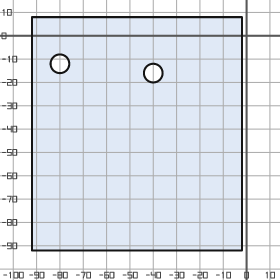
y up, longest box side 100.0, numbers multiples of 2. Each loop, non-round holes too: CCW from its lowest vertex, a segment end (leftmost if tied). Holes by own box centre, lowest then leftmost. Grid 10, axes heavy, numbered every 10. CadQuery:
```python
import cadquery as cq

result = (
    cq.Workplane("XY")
    .moveTo(-92.0, -92.0)
    .lineTo(-2.0, -92.0)
    .lineTo(-2.0, 8.0)
    .lineTo(-92.0, 8.0)
    .close()
    .moveTo(-40.0, -16.0)
    .circle(4.0)
    .moveTo(-80.0, -12.0)
    .circle(4.0)
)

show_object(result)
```